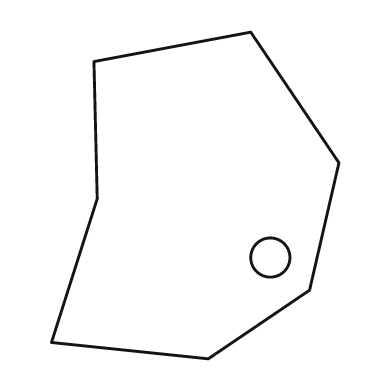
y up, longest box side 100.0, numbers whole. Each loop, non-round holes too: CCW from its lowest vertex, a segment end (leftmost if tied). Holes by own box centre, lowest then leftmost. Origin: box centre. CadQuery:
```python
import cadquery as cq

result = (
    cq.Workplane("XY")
    .moveTo(4.0, -50.0)
    .lineTo(35.0, -29.0)
    .lineTo(44.0, 10.0)
    .lineTo(17.0, 50.0)
    .lineTo(-31.0, 41.0)
    .lineTo(-30.0, -1.0)
    .lineTo(-44.0, -45.0)
    .close()
    .moveTo(23.0, -19.0)
    .circle(6.0)
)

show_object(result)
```